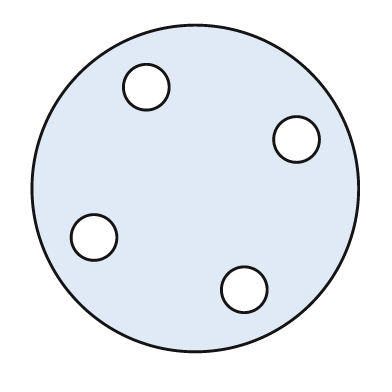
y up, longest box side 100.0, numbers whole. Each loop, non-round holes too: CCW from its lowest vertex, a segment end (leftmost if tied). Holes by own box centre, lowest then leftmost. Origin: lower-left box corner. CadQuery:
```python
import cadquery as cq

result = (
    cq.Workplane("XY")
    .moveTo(50.0, 50.0)
    .circle(50.0)
    .moveTo(65.0, 19.0)
    .circle(7.0)
    .moveTo(19.0, 35.0)
    .circle(7.0)
    .moveTo(81.0, 65.0)
    .circle(7.0)
    .moveTo(35.0, 81.0)
    .circle(7.0)
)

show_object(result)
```